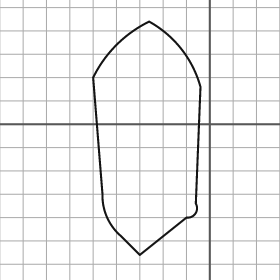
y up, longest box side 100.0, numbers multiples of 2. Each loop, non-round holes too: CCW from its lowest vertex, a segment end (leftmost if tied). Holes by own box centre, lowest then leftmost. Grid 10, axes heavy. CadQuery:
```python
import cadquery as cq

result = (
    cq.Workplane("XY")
    .moveTo(-30.0, -56.0)
    .lineTo(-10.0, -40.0)
    .threePointArc((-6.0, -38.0), (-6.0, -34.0))
    .lineTo(-4.0, 16.0)
    .threePointArc((-12.0, 32.0), (-26.0, 44.0))
    .threePointArc((-40.0, 34.0), (-50.0, 20.0))
    .lineTo(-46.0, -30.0)
    .threePointArc((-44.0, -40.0), (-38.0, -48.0))
    .close()
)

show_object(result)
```